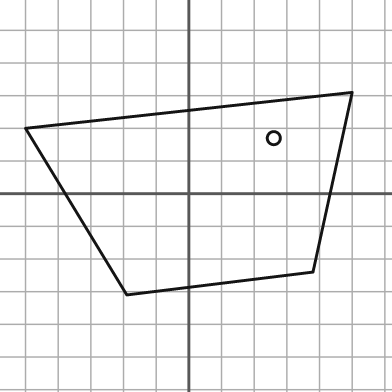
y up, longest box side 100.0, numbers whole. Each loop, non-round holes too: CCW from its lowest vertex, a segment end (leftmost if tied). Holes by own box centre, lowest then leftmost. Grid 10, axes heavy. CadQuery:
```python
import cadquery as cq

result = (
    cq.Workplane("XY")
    .moveTo(-19.0, -31.0)
    .lineTo(38.0, -24.0)
    .lineTo(50.0, 31.0)
    .lineTo(-50.0, 20.0)
    .close()
    .moveTo(26.0, 17.0)
    .circle(2.0)
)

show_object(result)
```